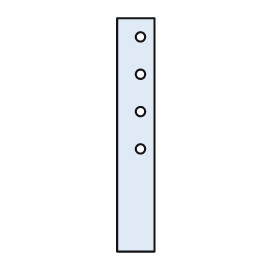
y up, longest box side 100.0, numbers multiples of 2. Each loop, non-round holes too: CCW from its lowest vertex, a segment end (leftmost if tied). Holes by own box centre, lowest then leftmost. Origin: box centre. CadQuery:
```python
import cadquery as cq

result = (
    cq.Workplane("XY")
    .moveTo(-8.0, -50.0)
    .lineTo(8.0, -50.0)
    .lineTo(8.0, 50.0)
    .lineTo(-8.0, 50.0)
    .close()
    .moveTo(2.0, -6.0)
    .circle(2.0)
    .moveTo(2.0, 10.0)
    .circle(2.0)
    .moveTo(2.0, 26.0)
    .circle(2.0)
    .moveTo(2.0, 42.0)
    .circle(2.0)
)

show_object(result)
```